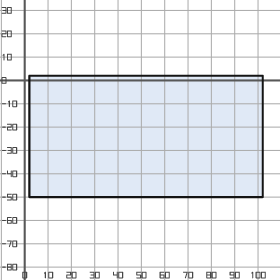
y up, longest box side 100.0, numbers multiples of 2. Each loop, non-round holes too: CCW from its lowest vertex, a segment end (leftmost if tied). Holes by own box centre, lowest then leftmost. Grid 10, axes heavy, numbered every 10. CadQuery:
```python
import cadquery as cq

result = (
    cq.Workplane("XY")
    .moveTo(2.0, -50.0)
    .lineTo(102.0, -50.0)
    .lineTo(102.0, 2.0)
    .lineTo(2.0, 2.0)
    .close()
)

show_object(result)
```